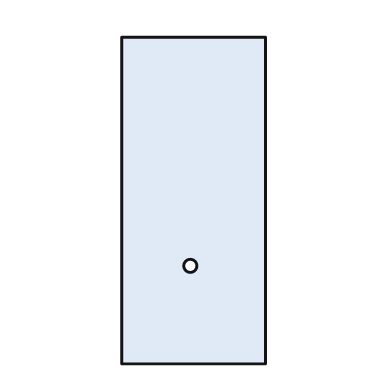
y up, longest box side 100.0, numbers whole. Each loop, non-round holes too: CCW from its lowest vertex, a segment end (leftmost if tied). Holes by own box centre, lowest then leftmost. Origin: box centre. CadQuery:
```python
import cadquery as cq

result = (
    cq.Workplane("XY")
    .moveTo(-22.0, -50.0)
    .lineTo(22.0, -50.0)
    .lineTo(22.0, 50.0)
    .lineTo(-22.0, 50.0)
    .close()
    .moveTo(-1.0, -20.0)
    .circle(2.0)
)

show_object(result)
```